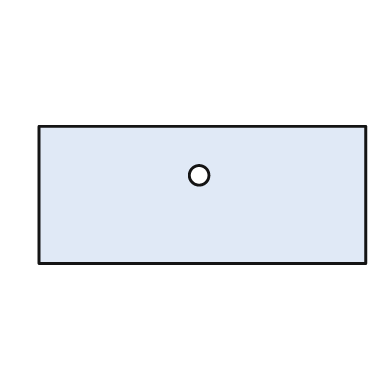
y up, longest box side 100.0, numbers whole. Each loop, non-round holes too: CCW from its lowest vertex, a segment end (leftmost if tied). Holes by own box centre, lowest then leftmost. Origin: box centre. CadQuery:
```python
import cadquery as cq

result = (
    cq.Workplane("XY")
    .moveTo(-50.0, -21.0)
    .lineTo(50.0, -21.0)
    .lineTo(50.0, 21.0)
    .lineTo(-50.0, 21.0)
    .close()
    .moveTo(-1.0, 6.0)
    .circle(3.0)
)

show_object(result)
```